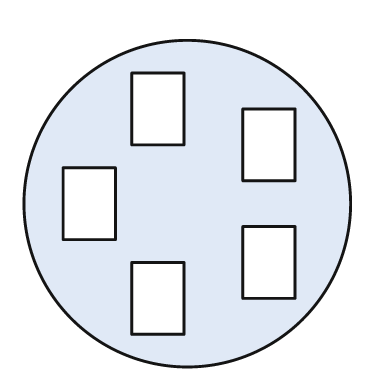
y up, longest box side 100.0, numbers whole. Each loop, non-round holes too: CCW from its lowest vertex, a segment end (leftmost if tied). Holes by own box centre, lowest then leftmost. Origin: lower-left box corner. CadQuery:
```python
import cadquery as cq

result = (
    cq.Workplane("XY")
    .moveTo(50.0, 50.0)
    .circle(50.0)
    .moveTo(33.0, 10.0)
    .lineTo(49.0, 10.0)
    .lineTo(49.0, 32.0)
    .lineTo(33.0, 32.0)
    .close()
    .moveTo(67.0, 21.0)
    .lineTo(83.0, 21.0)
    .lineTo(83.0, 43.0)
    .lineTo(67.0, 43.0)
    .close()
    .moveTo(12.0, 39.0)
    .lineTo(28.0, 39.0)
    .lineTo(28.0, 61.0)
    .lineTo(12.0, 61.0)
    .close()
    .moveTo(67.0, 57.0)
    .lineTo(83.0, 57.0)
    .lineTo(83.0, 79.0)
    .lineTo(67.0, 79.0)
    .close()
    .moveTo(33.0, 68.0)
    .lineTo(49.0, 68.0)
    .lineTo(49.0, 90.0)
    .lineTo(33.0, 90.0)
    .close()
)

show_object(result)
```